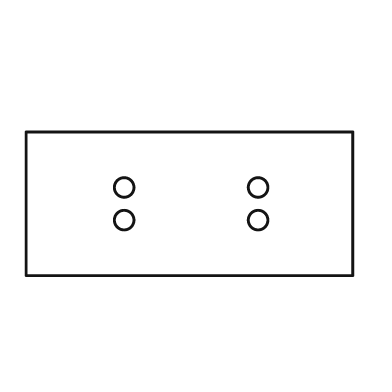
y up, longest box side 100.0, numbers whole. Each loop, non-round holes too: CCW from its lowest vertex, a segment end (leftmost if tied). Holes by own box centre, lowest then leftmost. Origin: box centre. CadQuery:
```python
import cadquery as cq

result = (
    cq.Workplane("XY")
    .moveTo(-50.0, -22.0)
    .lineTo(50.0, -22.0)
    .lineTo(50.0, 22.0)
    .lineTo(-50.0, 22.0)
    .close()
    .moveTo(-20.0, -5.0)
    .circle(3.0)
    .moveTo(21.0, -5.0)
    .circle(3.0)
    .moveTo(-20.0, 5.0)
    .circle(3.0)
    .moveTo(21.0, 5.0)
    .circle(3.0)
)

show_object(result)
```